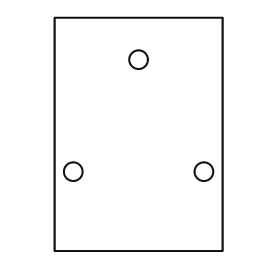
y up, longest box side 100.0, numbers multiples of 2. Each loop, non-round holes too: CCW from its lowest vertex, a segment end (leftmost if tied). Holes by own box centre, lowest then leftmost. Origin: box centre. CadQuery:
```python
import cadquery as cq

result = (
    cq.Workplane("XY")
    .moveTo(-36.0, -50.0)
    .lineTo(36.0, -50.0)
    .lineTo(36.0, 50.0)
    .lineTo(-36.0, 50.0)
    .close()
    .moveTo(-28.0, -16.0)
    .circle(4.0)
    .moveTo(28.0, -16.0)
    .circle(4.0)
    .moveTo(0.0, 32.0)
    .circle(4.0)
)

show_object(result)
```